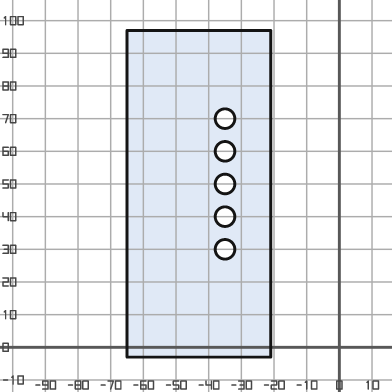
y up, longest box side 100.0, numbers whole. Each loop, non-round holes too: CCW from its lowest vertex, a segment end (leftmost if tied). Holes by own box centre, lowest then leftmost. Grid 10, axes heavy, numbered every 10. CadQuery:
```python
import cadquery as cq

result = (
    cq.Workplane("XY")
    .moveTo(-65.0, -3.0)
    .lineTo(-21.0, -3.0)
    .lineTo(-21.0, 97.0)
    .lineTo(-65.0, 97.0)
    .close()
    .moveTo(-35.0, 30.0)
    .circle(3.0)
    .moveTo(-35.0, 40.0)
    .circle(3.0)
    .moveTo(-35.0, 50.0)
    .circle(3.0)
    .moveTo(-35.0, 60.0)
    .circle(3.0)
    .moveTo(-35.0, 70.0)
    .circle(3.0)
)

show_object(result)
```